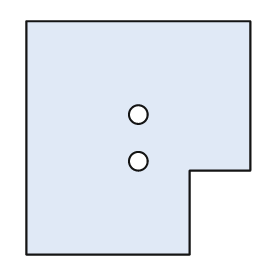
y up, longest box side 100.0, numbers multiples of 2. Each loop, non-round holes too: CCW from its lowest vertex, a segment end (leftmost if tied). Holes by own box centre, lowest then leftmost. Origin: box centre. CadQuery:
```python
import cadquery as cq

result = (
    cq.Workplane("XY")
    .moveTo(-48.0, -50.0)
    .lineTo(22.0, -50.0)
    .lineTo(22.0, -14.0)
    .lineTo(48.0, -14.0)
    .lineTo(48.0, 50.0)
    .lineTo(-48.0, 50.0)
    .close()
    .moveTo(0.0, -10.0)
    .circle(4.0)
    .moveTo(0.0, 10.0)
    .circle(4.0)
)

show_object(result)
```